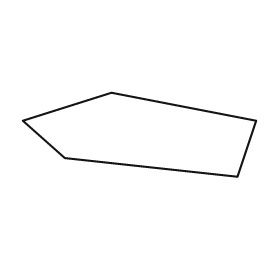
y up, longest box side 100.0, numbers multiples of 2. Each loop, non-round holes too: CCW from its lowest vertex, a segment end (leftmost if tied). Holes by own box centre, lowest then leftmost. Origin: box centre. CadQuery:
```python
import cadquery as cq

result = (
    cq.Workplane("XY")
    .moveTo(42.0, -18.0)
    .lineTo(50.0, 6.0)
    .lineTo(-12.0, 18.0)
    .lineTo(-50.0, 6.0)
    .lineTo(-32.0, -10.0)
    .close()
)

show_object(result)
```